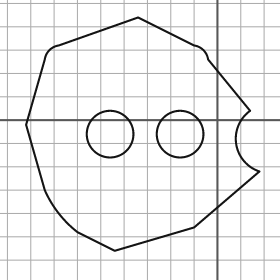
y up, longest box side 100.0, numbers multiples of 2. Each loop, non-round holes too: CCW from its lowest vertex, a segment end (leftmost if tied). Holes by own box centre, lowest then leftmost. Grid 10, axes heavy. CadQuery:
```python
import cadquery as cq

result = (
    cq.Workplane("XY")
    .moveTo(-44.0, -56.0)
    .lineTo(-10.0, -46.0)
    .lineTo(18.0, -22.0)
    .threePointArc((8.0, -10.0), (14.0, 4.0))
    .lineTo(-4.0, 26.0)
    .threePointArc((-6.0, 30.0), (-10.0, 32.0))
    .lineTo(-34.0, 44.0)
    .lineTo(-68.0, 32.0)
    .threePointArc((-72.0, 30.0), (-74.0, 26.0))
    .lineTo(-82.0, -2.0)
    .lineTo(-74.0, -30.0)
    .threePointArc((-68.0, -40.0), (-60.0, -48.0))
    .close()
    .moveTo(-46.0, -6.0)
    .circle(10.0)
    .moveTo(-16.0, -6.0)
    .circle(10.0)
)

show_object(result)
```